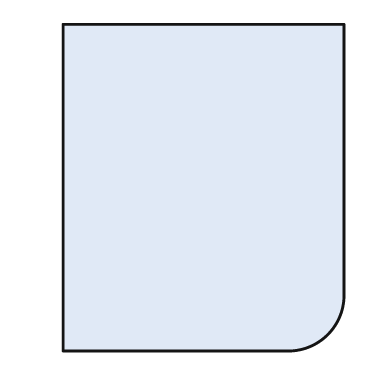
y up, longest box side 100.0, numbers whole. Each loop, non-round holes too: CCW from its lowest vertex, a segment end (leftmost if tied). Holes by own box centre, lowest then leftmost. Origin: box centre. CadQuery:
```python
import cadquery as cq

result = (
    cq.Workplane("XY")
    .moveTo(-43.0, -50.0)
    .lineTo(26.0, -50.0)
    .threePointArc((38.0, -45.0), (43.0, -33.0))
    .lineTo(43.0, 50.0)
    .lineTo(-43.0, 50.0)
    .close()
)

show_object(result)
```